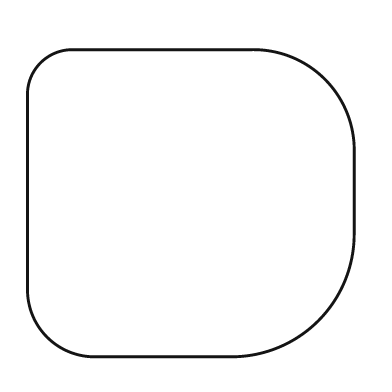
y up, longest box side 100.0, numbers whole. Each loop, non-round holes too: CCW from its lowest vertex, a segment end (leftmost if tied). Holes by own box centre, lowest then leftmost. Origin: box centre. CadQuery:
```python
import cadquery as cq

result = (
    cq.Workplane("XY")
    .moveTo(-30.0, -47.0)
    .lineTo(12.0, -47.0)
    .threePointArc((39.0, -36.0), (50.0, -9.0))
    .lineTo(50.0, 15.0)
    .threePointArc((41.0, 38.0), (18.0, 47.0))
    .lineTo(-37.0, 47.0)
    .threePointArc((-46.0, 43.0), (-50.0, 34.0))
    .lineTo(-50.0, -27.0)
    .threePointArc((-44.0, -41.0), (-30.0, -47.0))
    .close()
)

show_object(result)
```